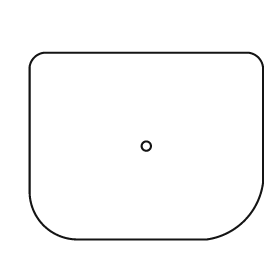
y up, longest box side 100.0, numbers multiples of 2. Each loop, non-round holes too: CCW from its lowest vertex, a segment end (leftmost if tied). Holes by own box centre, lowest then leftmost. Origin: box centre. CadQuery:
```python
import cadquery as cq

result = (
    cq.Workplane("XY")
    .moveTo(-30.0, -40.0)
    .lineTo(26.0, -40.0)
    .threePointArc((42.0, -32.0), (50.0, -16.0))
    .lineTo(50.0, 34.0)
    .threePointArc((48.0, 38.0), (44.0, 40.0))
    .lineTo(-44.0, 40.0)
    .threePointArc((-48.0, 38.0), (-50.0, 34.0))
    .lineTo(-50.0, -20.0)
    .threePointArc((-44.0, -34.0), (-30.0, -40.0))
    .close()
    .moveTo(0.0, 0.0)
    .circle(2.0)
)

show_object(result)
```